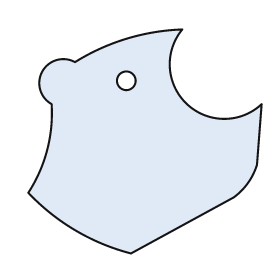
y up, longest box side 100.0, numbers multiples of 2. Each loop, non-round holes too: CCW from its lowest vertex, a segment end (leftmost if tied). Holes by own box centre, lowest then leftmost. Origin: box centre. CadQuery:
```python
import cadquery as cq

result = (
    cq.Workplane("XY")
    .moveTo(-6.0, -48.0)
    .lineTo(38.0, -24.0)
    .threePointArc((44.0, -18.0), (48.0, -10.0))
    .lineTo(50.0, 16.0)
    .threePointArc((18.0, 16.0), (16.0, 48.0))
    .threePointArc((-8.0, 44.0), (-30.0, 34.0))
    .threePointArc((-44.0, 30.0), (-40.0, 16.0))
    .threePointArc((-42.0, -4.0), (-50.0, -22.0))
    .threePointArc((-30.0, -38.0), (-6.0, -48.0))
    .close()
    .moveTo(-8.0, 26.0)
    .circle(4.0)
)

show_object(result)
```